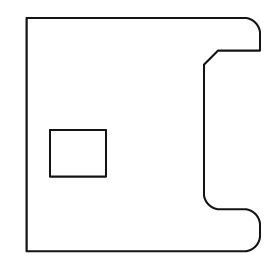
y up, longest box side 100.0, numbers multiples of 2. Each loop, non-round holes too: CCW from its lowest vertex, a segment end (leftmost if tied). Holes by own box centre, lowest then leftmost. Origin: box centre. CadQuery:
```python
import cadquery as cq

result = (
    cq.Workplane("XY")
    .moveTo(-50.0, -50.0)
    .lineTo(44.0, -50.0)
    .threePointArc((48.0, -48.0), (50.0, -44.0))
    .lineTo(50.0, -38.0)
    .threePointArc((48.0, -34.0), (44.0, -32.0))
    .lineTo(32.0, -32.0)
    .threePointArc((28.0, -30.0), (26.0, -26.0))
    .lineTo(26.0, 30.0)
    .lineTo(32.0, 36.0)
    .lineTo(50.0, 36.0)
    .lineTo(50.0, 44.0)
    .threePointArc((48.0, 48.0), (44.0, 50.0))
    .lineTo(-50.0, 50.0)
    .close()
    .moveTo(-40.0, -18.0)
    .lineTo(-16.0, -18.0)
    .lineTo(-16.0, 2.0)
    .lineTo(-40.0, 2.0)
    .close()
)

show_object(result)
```